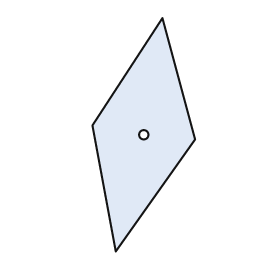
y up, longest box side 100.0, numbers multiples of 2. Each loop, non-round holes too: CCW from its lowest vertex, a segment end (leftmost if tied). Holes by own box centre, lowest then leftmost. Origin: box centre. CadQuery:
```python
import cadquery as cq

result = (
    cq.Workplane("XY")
    .moveTo(-12.0, -50.0)
    .lineTo(22.0, -2.0)
    .lineTo(8.0, 50.0)
    .lineTo(-22.0, 4.0)
    .close()
    .moveTo(0.0, 0.0)
    .circle(2.0)
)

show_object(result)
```